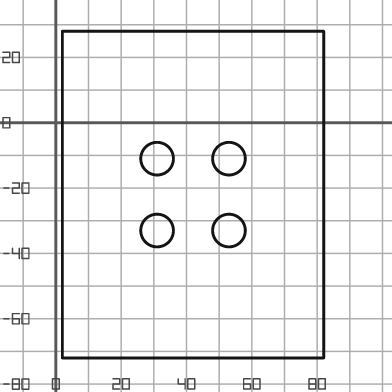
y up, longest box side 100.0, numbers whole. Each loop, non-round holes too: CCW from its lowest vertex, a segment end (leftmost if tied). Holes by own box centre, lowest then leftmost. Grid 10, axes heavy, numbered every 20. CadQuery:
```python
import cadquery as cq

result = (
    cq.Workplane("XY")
    .moveTo(2.0, -72.0)
    .lineTo(82.0, -72.0)
    .lineTo(82.0, 28.0)
    .lineTo(2.0, 28.0)
    .close()
    .moveTo(31.0, -33.0)
    .circle(5.0)
    .moveTo(53.0, -33.0)
    .circle(5.0)
    .moveTo(31.0, -11.0)
    .circle(5.0)
    .moveTo(53.0, -11.0)
    .circle(5.0)
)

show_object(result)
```